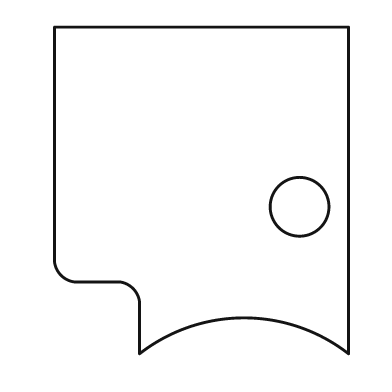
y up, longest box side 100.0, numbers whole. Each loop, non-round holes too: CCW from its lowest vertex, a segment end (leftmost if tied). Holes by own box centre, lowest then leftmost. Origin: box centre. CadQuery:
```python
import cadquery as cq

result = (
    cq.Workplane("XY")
    .moveTo(-19.0, -50.0)
    .threePointArc((13.0, -39.0), (45.0, -50.0))
    .lineTo(45.0, 50.0)
    .lineTo(-45.0, 50.0)
    .lineTo(-45.0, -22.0)
    .threePointArc((-43.0, -26.0), (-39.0, -28.0))
    .lineTo(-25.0, -28.0)
    .threePointArc((-21.0, -30.0), (-19.0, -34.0))
    .close()
    .moveTo(30.0, -5.0)
    .circle(9.0)
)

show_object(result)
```